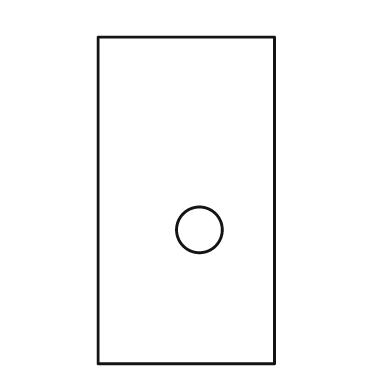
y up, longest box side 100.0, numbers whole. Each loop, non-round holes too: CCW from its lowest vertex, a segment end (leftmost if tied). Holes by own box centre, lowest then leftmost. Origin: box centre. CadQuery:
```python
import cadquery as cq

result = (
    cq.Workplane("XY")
    .moveTo(-27.0, -50.0)
    .lineTo(27.0, -50.0)
    .lineTo(27.0, 50.0)
    .lineTo(-27.0, 50.0)
    .close()
    .moveTo(4.0, -9.0)
    .circle(7.0)
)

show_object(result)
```